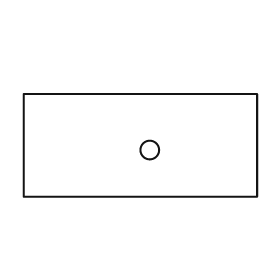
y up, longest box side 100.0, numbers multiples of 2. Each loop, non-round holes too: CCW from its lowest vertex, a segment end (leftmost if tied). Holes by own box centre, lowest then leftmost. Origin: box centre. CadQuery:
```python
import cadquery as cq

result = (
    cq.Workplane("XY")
    .moveTo(-50.0, -22.0)
    .lineTo(50.0, -22.0)
    .lineTo(50.0, 22.0)
    .lineTo(-50.0, 22.0)
    .close()
    .moveTo(4.0, -2.0)
    .circle(4.0)
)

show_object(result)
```